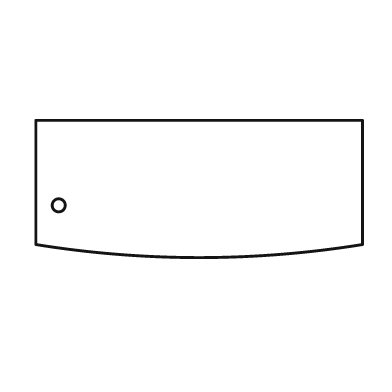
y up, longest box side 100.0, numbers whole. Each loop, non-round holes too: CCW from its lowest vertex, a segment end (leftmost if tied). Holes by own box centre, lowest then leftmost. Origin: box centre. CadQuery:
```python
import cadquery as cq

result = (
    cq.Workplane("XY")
    .moveTo(-50.0, -17.0)
    .threePointArc((0.0, -21.0), (50.0, -17.0))
    .lineTo(50.0, 21.0)
    .lineTo(-50.0, 21.0)
    .close()
    .moveTo(-43.0, -5.0)
    .circle(2.0)
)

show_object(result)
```